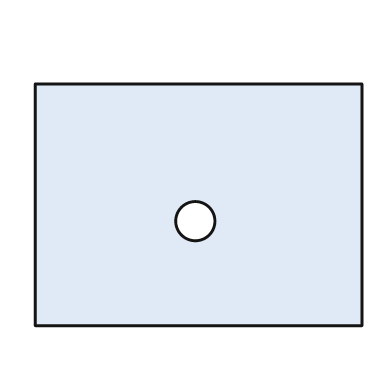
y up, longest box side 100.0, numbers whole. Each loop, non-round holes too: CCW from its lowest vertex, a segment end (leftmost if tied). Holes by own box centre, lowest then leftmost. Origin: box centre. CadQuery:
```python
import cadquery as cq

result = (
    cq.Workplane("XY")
    .moveTo(-50.0, -37.0)
    .lineTo(50.0, -37.0)
    .lineTo(50.0, 37.0)
    .lineTo(-50.0, 37.0)
    .close()
    .moveTo(-1.0, -5.0)
    .circle(6.0)
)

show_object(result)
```